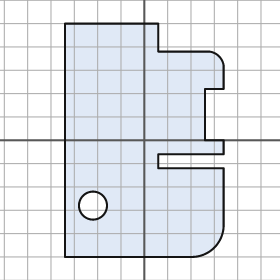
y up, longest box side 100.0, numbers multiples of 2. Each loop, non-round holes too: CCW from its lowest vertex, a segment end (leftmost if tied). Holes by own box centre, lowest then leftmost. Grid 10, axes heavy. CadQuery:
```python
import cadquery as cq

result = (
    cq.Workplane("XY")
    .moveTo(-34.0, -50.0)
    .lineTo(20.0, -50.0)
    .threePointArc((30.0, -46.0), (34.0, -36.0))
    .lineTo(34.0, -12.0)
    .lineTo(6.0, -12.0)
    .lineTo(6.0, -6.0)
    .lineTo(34.0, -6.0)
    .lineTo(34.0, 0.0)
    .lineTo(26.0, 0.0)
    .lineTo(26.0, 22.0)
    .lineTo(34.0, 22.0)
    .lineTo(34.0, 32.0)
    .threePointArc((32.0, 36.0), (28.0, 38.0))
    .lineTo(6.0, 38.0)
    .lineTo(6.0, 50.0)
    .lineTo(-34.0, 50.0)
    .close()
    .moveTo(-22.0, -28.0)
    .circle(6.0)
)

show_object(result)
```